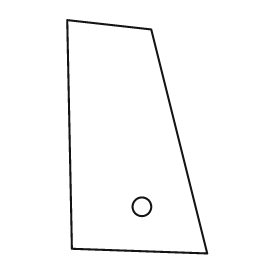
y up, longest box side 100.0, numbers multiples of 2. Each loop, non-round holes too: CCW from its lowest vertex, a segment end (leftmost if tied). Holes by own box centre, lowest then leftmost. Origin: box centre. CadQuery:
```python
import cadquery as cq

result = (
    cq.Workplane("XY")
    .moveTo(30.0, -50.0)
    .lineTo(6.0, 46.0)
    .lineTo(-30.0, 50.0)
    .lineTo(-28.0, -48.0)
    .close()
    .moveTo(2.0, -30.0)
    .circle(4.0)
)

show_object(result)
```